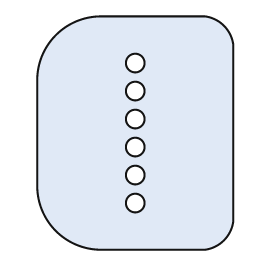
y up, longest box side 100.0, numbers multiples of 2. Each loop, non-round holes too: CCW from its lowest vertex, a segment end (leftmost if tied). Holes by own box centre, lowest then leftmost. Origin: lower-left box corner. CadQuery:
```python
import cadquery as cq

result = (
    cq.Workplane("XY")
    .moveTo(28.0, 0.0)
    .lineTo(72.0, 0.0)
    .threePointArc((80.0, 4.0), (84.0, 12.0))
    .lineTo(84.0, 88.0)
    .threePointArc((80.0, 96.0), (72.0, 100.0))
    .lineTo(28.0, 100.0)
    .threePointArc((8.0, 92.0), (0.0, 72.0))
    .lineTo(0.0, 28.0)
    .threePointArc((8.0, 8.0), (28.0, 0.0))
    .close()
    .moveTo(42.0, 20.0)
    .circle(4.0)
    .moveTo(42.0, 32.0)
    .circle(4.0)
    .moveTo(42.0, 44.0)
    .circle(4.0)
    .moveTo(42.0, 56.0)
    .circle(4.0)
    .moveTo(42.0, 68.0)
    .circle(4.0)
    .moveTo(42.0, 80.0)
    .circle(4.0)
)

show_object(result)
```